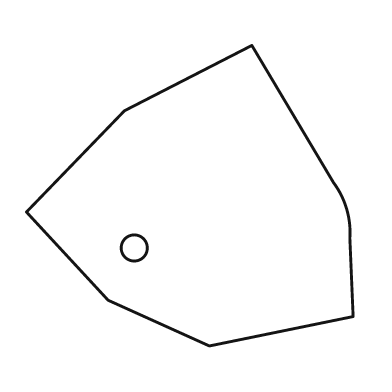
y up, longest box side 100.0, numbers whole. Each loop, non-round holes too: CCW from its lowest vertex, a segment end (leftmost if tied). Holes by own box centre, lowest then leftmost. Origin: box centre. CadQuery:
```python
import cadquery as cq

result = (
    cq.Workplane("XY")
    .moveTo(6.0, -46.0)
    .lineTo(50.0, -37.0)
    .lineTo(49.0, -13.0)
    .threePointArc((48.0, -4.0), (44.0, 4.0))
    .lineTo(19.0, 46.0)
    .lineTo(-20.0, 26.0)
    .lineTo(-50.0, -5.0)
    .lineTo(-25.0, -32.0)
    .close()
    .moveTo(-17.0, -16.0)
    .circle(4.0)
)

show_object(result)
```